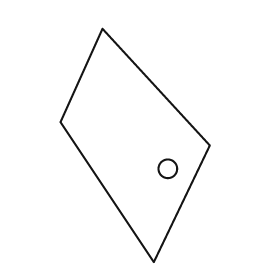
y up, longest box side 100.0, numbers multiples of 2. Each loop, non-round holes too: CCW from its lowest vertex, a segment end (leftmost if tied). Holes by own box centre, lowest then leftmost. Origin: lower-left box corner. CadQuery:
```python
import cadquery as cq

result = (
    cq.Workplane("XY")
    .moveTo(40.0, 0.0)
    .lineTo(64.0, 50.0)
    .lineTo(18.0, 100.0)
    .lineTo(0.0, 60.0)
    .close()
    .moveTo(46.0, 40.0)
    .circle(4.0)
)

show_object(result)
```